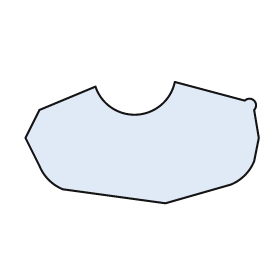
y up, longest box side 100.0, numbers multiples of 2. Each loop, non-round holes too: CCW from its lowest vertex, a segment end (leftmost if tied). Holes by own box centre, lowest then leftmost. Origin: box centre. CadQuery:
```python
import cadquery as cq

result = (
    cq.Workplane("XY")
    .moveTo(10.0, -26.0)
    .lineTo(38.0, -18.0)
    .threePointArc((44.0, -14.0), (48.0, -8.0))
    .lineTo(50.0, 2.0)
    .lineTo(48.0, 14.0)
    .threePointArc((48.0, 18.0), (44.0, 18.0))
    .lineTo(14.0, 26.0)
    .threePointArc((-2.0, 12.0), (-20.0, 24.0))
    .lineTo(-44.0, 14.0)
    .lineTo(-50.0, 2.0)
    .lineTo(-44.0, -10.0)
    .threePointArc((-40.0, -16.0), (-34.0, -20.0))
    .close()
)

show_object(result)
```